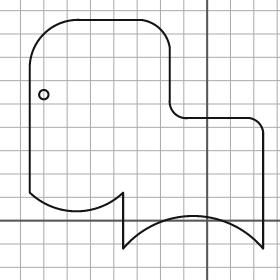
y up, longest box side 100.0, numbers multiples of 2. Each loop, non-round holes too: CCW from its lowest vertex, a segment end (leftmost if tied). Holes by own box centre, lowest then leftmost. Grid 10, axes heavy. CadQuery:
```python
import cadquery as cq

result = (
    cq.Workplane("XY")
    .moveTo(-36.0, -12.0)
    .threePointArc((-6.0, 2.0), (24.0, -12.0))
    .lineTo(24.0, 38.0)
    .threePointArc((22.0, 42.0), (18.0, 44.0))
    .lineTo(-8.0, 44.0)
    .threePointArc((-14.0, 46.0), (-16.0, 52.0))
    .lineTo(-16.0, 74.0)
    .threePointArc((-20.0, 82.0), (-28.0, 86.0))
    .lineTo(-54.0, 86.0)
    .threePointArc((-70.0, 80.0), (-76.0, 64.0))
    .lineTo(-76.0, 12.0)
    .threePointArc((-56.0, 4.0), (-36.0, 12.0))
    .close()
    .moveTo(-70.0, 54.0)
    .circle(2.0)
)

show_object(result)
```